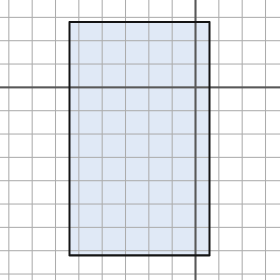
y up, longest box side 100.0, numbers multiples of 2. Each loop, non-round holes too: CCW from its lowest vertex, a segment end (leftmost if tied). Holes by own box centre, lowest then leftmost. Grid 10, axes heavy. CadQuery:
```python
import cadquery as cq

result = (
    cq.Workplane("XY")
    .moveTo(-54.0, -72.0)
    .lineTo(6.0, -72.0)
    .lineTo(6.0, 28.0)
    .lineTo(-54.0, 28.0)
    .close()
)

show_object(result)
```